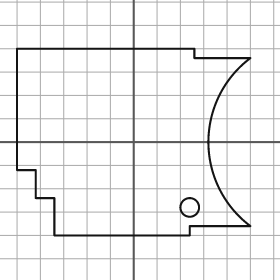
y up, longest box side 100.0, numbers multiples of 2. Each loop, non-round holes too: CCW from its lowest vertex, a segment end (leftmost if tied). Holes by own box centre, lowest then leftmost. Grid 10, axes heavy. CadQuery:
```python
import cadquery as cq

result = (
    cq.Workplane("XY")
    .moveTo(-34.0, -40.0)
    .lineTo(24.0, -40.0)
    .lineTo(24.0, -36.0)
    .lineTo(50.0, -36.0)
    .threePointArc((32.0, 0.0), (50.0, 36.0))
    .lineTo(26.0, 36.0)
    .lineTo(26.0, 40.0)
    .lineTo(-50.0, 40.0)
    .lineTo(-50.0, -12.0)
    .lineTo(-42.0, -12.0)
    .lineTo(-42.0, -24.0)
    .lineTo(-34.0, -24.0)
    .close()
    .moveTo(24.0, -28.0)
    .circle(4.0)
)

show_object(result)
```